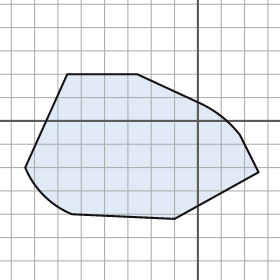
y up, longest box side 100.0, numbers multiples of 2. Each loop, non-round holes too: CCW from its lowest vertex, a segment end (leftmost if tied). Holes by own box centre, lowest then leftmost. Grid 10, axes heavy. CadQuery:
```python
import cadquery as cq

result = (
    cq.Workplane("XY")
    .moveTo(-10.0, -42.0)
    .lineTo(26.0, -22.0)
    .lineTo(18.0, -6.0)
    .threePointArc((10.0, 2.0), (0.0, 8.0))
    .lineTo(-26.0, 20.0)
    .lineTo(-56.0, 20.0)
    .lineTo(-74.0, -20.0)
    .threePointArc((-66.0, -32.0), (-54.0, -40.0))
    .close()
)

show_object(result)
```